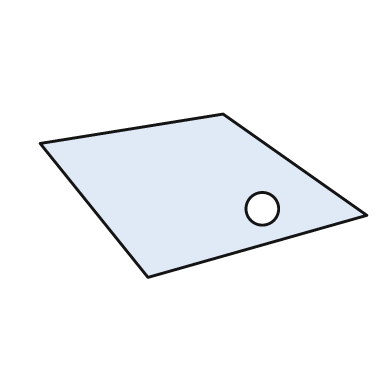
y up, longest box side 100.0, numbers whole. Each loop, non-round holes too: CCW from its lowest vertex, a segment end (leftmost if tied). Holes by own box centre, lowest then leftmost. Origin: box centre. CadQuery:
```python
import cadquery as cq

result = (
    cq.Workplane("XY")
    .moveTo(-17.0, -25.0)
    .lineTo(50.0, -6.0)
    .lineTo(6.0, 25.0)
    .lineTo(-50.0, 16.0)
    .close()
    .moveTo(18.0, -4.0)
    .circle(5.0)
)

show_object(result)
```